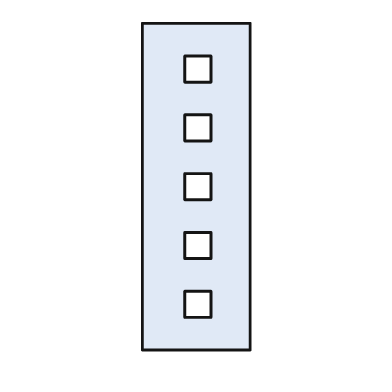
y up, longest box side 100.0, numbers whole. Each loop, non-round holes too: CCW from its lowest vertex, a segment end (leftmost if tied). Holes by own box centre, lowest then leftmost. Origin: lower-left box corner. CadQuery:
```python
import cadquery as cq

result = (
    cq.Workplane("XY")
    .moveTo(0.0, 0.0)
    .lineTo(33.0, 0.0)
    .lineTo(33.0, 100.0)
    .lineTo(0.0, 100.0)
    .close()
    .moveTo(13.0, 10.0)
    .lineTo(21.0, 10.0)
    .lineTo(21.0, 18.0)
    .lineTo(13.0, 18.0)
    .close()
    .moveTo(13.0, 28.0)
    .lineTo(21.0, 28.0)
    .lineTo(21.0, 36.0)
    .lineTo(13.0, 36.0)
    .close()
    .moveTo(13.0, 46.0)
    .lineTo(21.0, 46.0)
    .lineTo(21.0, 54.0)
    .lineTo(13.0, 54.0)
    .close()
    .moveTo(13.0, 64.0)
    .lineTo(21.0, 64.0)
    .lineTo(21.0, 72.0)
    .lineTo(13.0, 72.0)
    .close()
    .moveTo(13.0, 82.0)
    .lineTo(21.0, 82.0)
    .lineTo(21.0, 90.0)
    .lineTo(13.0, 90.0)
    .close()
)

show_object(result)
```